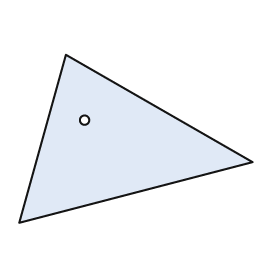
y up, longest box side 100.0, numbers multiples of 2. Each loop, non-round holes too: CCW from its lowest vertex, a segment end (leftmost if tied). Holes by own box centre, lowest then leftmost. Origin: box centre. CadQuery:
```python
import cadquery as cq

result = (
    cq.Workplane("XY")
    .moveTo(-50.0, -36.0)
    .lineTo(50.0, -10.0)
    .lineTo(-30.0, 36.0)
    .close()
    .moveTo(-22.0, 8.0)
    .circle(2.0)
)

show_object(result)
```